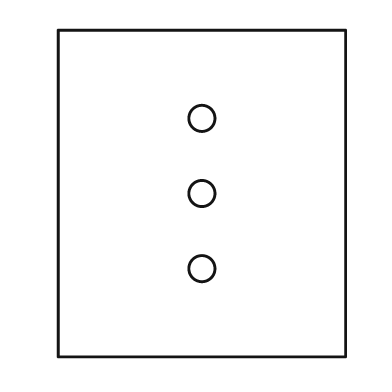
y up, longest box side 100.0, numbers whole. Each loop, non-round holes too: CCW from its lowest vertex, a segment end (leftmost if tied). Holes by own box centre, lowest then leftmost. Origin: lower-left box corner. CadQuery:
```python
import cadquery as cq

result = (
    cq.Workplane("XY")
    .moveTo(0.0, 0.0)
    .lineTo(88.0, 0.0)
    .lineTo(88.0, 100.0)
    .lineTo(0.0, 100.0)
    .close()
    .moveTo(44.0, 27.0)
    .circle(4.0)
    .moveTo(44.0, 50.0)
    .circle(4.0)
    .moveTo(44.0, 73.0)
    .circle(4.0)
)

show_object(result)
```